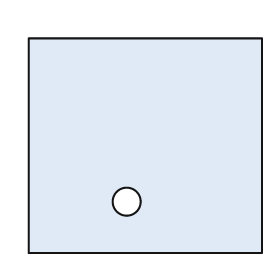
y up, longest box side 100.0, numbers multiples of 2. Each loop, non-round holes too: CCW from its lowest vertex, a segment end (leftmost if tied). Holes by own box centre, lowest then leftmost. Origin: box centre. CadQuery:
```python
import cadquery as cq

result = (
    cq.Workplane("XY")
    .moveTo(-50.0, -46.0)
    .lineTo(50.0, -46.0)
    .lineTo(50.0, 46.0)
    .lineTo(-50.0, 46.0)
    .close()
    .moveTo(-8.0, -24.0)
    .circle(6.0)
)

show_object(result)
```